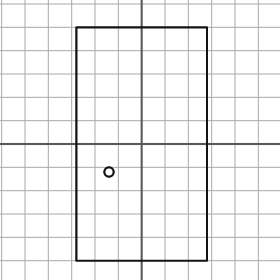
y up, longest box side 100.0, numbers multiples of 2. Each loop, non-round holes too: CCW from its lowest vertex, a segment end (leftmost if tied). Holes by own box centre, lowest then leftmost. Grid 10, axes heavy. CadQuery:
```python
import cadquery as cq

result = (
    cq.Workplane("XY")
    .moveTo(-28.0, -50.0)
    .lineTo(28.0, -50.0)
    .lineTo(28.0, 50.0)
    .lineTo(-28.0, 50.0)
    .close()
    .moveTo(-14.0, -12.0)
    .circle(2.0)
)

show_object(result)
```